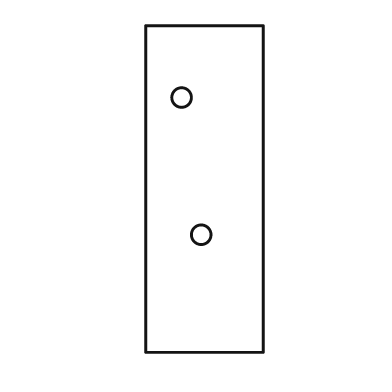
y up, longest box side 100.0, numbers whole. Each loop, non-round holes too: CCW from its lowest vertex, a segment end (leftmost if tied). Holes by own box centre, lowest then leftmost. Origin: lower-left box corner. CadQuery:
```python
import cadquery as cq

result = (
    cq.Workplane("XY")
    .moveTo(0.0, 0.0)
    .lineTo(36.0, 0.0)
    .lineTo(36.0, 100.0)
    .lineTo(0.0, 100.0)
    .close()
    .moveTo(17.0, 36.0)
    .circle(3.0)
    .moveTo(11.0, 78.0)
    .circle(3.0)
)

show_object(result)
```